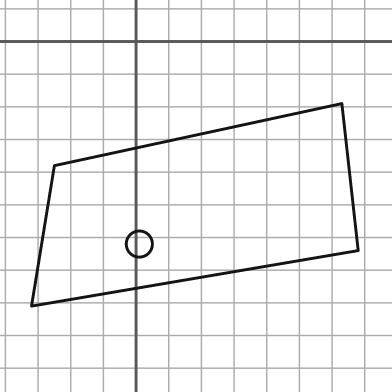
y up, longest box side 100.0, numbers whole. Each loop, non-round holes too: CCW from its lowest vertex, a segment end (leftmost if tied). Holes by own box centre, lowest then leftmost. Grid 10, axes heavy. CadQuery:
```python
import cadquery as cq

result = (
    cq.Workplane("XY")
    .moveTo(-32.0, -81.0)
    .lineTo(68.0, -64.0)
    .lineTo(63.0, -19.0)
    .lineTo(-25.0, -38.0)
    .close()
    .moveTo(1.0, -62.0)
    .circle(4.0)
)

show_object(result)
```